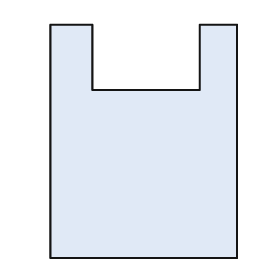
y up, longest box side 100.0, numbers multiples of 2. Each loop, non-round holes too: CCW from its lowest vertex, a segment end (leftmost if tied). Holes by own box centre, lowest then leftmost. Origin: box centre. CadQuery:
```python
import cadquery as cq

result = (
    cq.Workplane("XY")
    .moveTo(-40.0, -50.0)
    .lineTo(40.0, -50.0)
    .lineTo(40.0, 50.0)
    .lineTo(24.0, 50.0)
    .lineTo(24.0, 22.0)
    .lineTo(-22.0, 22.0)
    .lineTo(-22.0, 50.0)
    .lineTo(-40.0, 50.0)
    .close()
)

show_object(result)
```